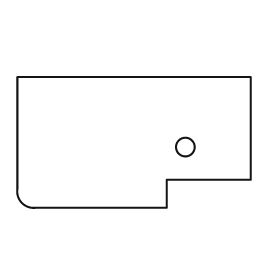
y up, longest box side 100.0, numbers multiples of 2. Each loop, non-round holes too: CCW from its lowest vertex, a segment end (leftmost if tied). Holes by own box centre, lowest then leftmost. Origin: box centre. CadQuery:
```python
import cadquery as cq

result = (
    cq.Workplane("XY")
    .moveTo(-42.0, -28.0)
    .lineTo(14.0, -28.0)
    .lineTo(14.0, -16.0)
    .lineTo(50.0, -16.0)
    .lineTo(50.0, 28.0)
    .lineTo(-50.0, 28.0)
    .lineTo(-50.0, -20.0)
    .threePointArc((-48.0, -26.0), (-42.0, -28.0))
    .close()
    .moveTo(22.0, -2.0)
    .circle(4.0)
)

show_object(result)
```